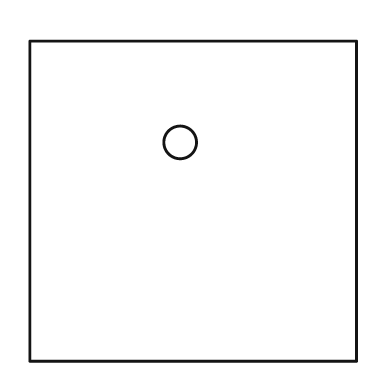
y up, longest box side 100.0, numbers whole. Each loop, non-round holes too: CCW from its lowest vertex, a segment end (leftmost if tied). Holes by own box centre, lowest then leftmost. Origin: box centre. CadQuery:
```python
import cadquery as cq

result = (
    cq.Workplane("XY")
    .moveTo(-50.0, -49.0)
    .lineTo(50.0, -49.0)
    .lineTo(50.0, 49.0)
    .lineTo(-50.0, 49.0)
    .close()
    .moveTo(-4.0, 18.0)
    .circle(5.0)
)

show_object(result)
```